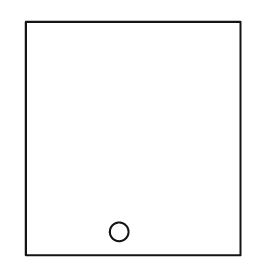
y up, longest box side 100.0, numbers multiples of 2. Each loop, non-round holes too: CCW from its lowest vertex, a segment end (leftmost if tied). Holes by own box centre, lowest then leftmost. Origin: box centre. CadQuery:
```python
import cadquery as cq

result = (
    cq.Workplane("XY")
    .moveTo(-46.0, -50.0)
    .lineTo(46.0, -50.0)
    .lineTo(46.0, 50.0)
    .lineTo(-46.0, 50.0)
    .close()
    .moveTo(-6.0, -40.0)
    .circle(4.0)
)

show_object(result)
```